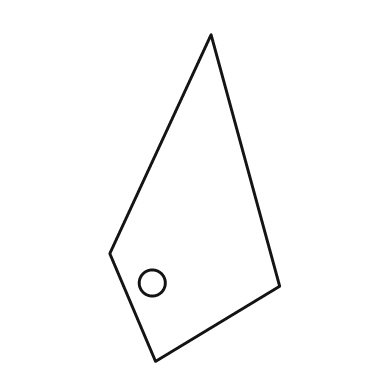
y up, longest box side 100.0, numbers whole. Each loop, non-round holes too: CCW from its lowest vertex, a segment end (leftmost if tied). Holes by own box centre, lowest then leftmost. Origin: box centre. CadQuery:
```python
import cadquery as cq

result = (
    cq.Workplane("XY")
    .moveTo(-12.0, -50.0)
    .lineTo(26.0, -27.0)
    .lineTo(5.0, 50.0)
    .lineTo(-26.0, -17.0)
    .close()
    .moveTo(-13.0, -26.0)
    .circle(4.0)
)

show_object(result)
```